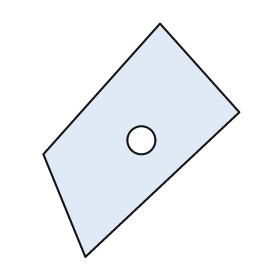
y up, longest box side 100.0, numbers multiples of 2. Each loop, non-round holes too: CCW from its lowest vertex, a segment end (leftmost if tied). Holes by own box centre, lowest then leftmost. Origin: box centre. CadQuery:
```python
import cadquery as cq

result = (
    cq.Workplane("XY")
    .moveTo(-24.0, -50.0)
    .lineTo(42.0, 12.0)
    .lineTo(8.0, 50.0)
    .lineTo(-42.0, -6.0)
    .close()
    .moveTo(0.0, 0.0)
    .circle(6.0)
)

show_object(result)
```